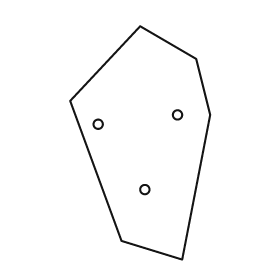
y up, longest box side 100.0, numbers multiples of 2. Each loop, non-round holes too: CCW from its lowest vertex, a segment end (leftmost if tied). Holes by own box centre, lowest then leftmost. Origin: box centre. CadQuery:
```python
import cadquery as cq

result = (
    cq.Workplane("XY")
    .moveTo(18.0, -50.0)
    .lineTo(30.0, 12.0)
    .lineTo(24.0, 36.0)
    .lineTo(0.0, 50.0)
    .lineTo(-30.0, 18.0)
    .lineTo(-8.0, -42.0)
    .close()
    .moveTo(2.0, -20.0)
    .circle(2.0)
    .moveTo(-18.0, 8.0)
    .circle(2.0)
    .moveTo(16.0, 12.0)
    .circle(2.0)
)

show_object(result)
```